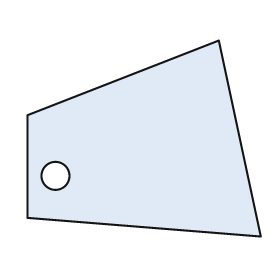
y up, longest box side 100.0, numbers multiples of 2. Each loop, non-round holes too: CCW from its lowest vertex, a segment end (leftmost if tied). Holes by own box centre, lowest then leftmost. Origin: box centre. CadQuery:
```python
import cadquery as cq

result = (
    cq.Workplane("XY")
    .moveTo(50.0, -42.0)
    .lineTo(32.0, 42.0)
    .lineTo(-50.0, 10.0)
    .lineTo(-50.0, -34.0)
    .close()
    .moveTo(-38.0, -16.0)
    .circle(6.0)
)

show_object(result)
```